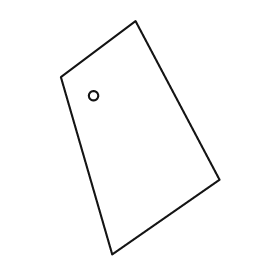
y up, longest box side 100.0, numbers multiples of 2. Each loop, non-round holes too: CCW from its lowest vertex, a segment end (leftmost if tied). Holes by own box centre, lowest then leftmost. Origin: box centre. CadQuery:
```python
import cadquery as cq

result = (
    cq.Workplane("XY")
    .moveTo(-12.0, -50.0)
    .lineTo(34.0, -18.0)
    .lineTo(-2.0, 50.0)
    .lineTo(-34.0, 26.0)
    .close()
    .moveTo(-20.0, 18.0)
    .circle(2.0)
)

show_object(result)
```